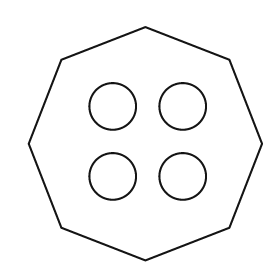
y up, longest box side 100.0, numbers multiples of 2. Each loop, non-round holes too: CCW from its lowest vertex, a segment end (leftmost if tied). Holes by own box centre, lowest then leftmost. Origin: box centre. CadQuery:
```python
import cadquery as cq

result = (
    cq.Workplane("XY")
    .moveTo(0.0, -50.0)
    .lineTo(36.0, -36.0)
    .lineTo(50.0, 0.0)
    .lineTo(36.0, 36.0)
    .lineTo(0.0, 50.0)
    .lineTo(-36.0, 36.0)
    .lineTo(-50.0, 0.0)
    .lineTo(-36.0, -36.0)
    .close()
    .moveTo(-14.0, -14.0)
    .circle(10.0)
    .moveTo(16.0, -14.0)
    .circle(10.0)
    .moveTo(-14.0, 16.0)
    .circle(10.0)
    .moveTo(16.0, 16.0)
    .circle(10.0)
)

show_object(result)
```